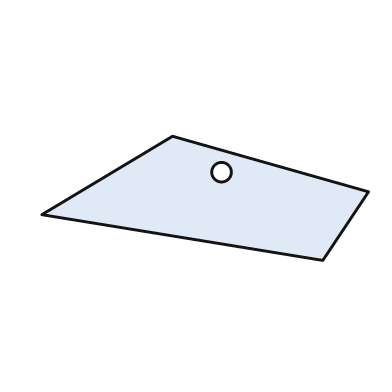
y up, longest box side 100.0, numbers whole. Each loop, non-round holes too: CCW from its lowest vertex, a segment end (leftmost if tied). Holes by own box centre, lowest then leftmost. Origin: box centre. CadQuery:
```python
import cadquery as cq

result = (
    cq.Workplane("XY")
    .moveTo(36.0, -19.0)
    .lineTo(50.0, 2.0)
    .lineTo(-10.0, 19.0)
    .lineTo(-50.0, -5.0)
    .close()
    .moveTo(5.0, 8.0)
    .circle(3.0)
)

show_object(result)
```